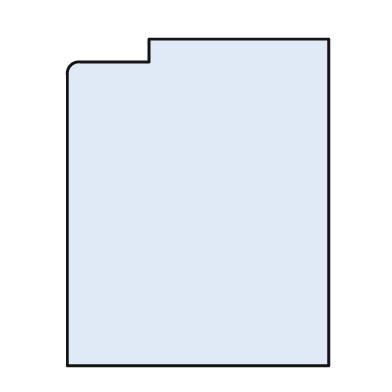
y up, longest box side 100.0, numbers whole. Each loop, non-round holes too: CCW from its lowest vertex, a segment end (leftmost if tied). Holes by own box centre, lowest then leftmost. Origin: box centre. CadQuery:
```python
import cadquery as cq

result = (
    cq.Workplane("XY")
    .moveTo(-40.0, -50.0)
    .lineTo(40.0, -50.0)
    .lineTo(40.0, 50.0)
    .lineTo(-15.0, 50.0)
    .lineTo(-15.0, 43.0)
    .lineTo(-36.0, 43.0)
    .threePointArc((-39.0, 42.0), (-40.0, 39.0))
    .close()
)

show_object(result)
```